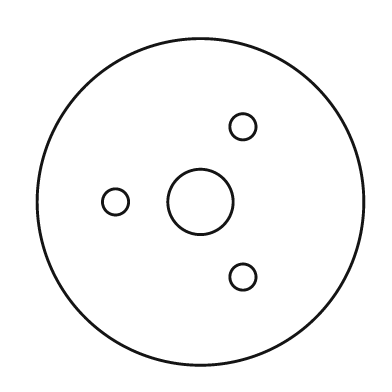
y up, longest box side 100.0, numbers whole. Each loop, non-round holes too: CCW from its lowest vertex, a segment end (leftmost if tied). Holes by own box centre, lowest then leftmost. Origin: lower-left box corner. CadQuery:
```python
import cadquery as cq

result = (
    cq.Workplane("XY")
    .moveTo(50.0, 50.0)
    .circle(50.0)
    .moveTo(63.0, 27.0)
    .circle(4.0)
    .moveTo(24.0, 50.0)
    .circle(4.0)
    .moveTo(50.0, 50.0)
    .circle(10.0)
    .moveTo(63.0, 73.0)
    .circle(4.0)
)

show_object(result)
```